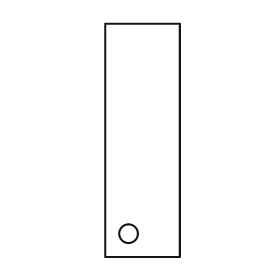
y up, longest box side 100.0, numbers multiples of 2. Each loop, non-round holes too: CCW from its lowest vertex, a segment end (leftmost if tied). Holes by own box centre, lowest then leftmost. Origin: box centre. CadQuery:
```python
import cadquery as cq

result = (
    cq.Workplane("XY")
    .moveTo(-16.0, -50.0)
    .lineTo(16.0, -50.0)
    .lineTo(16.0, 50.0)
    .lineTo(-16.0, 50.0)
    .close()
    .moveTo(-6.0, -40.0)
    .circle(4.0)
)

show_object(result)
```